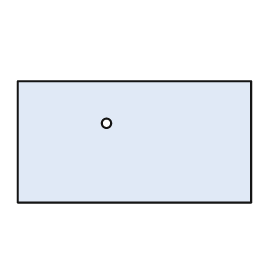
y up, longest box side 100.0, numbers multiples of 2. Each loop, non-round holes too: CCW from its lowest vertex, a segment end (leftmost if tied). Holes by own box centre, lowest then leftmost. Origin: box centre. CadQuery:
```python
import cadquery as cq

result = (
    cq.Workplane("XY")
    .moveTo(-50.0, -26.0)
    .lineTo(50.0, -26.0)
    .lineTo(50.0, 26.0)
    .lineTo(-50.0, 26.0)
    .close()
    .moveTo(-12.0, 8.0)
    .circle(2.0)
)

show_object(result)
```